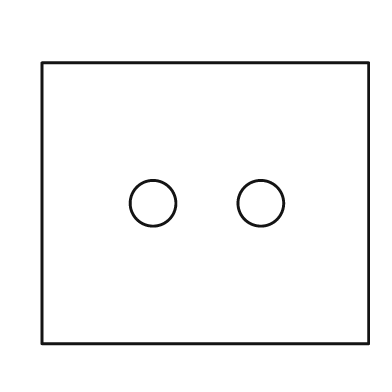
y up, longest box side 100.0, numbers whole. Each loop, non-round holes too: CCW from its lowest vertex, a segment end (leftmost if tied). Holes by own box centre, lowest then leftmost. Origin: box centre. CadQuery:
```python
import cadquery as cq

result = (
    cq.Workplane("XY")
    .moveTo(-50.0, -43.0)
    .lineTo(50.0, -43.0)
    .lineTo(50.0, 43.0)
    .lineTo(-50.0, 43.0)
    .close()
    .moveTo(-16.0, 0.0)
    .circle(7.0)
    .moveTo(17.0, 0.0)
    .circle(7.0)
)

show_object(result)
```